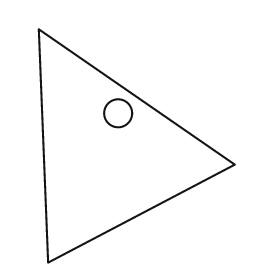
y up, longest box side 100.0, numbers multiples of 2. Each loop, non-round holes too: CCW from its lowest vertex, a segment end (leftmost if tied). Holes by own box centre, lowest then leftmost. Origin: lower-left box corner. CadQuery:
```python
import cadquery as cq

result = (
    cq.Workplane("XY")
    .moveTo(4.0, 0.0)
    .lineTo(84.0, 42.0)
    .lineTo(0.0, 100.0)
    .close()
    .moveTo(34.0, 64.0)
    .circle(6.0)
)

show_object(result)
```